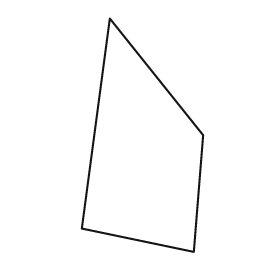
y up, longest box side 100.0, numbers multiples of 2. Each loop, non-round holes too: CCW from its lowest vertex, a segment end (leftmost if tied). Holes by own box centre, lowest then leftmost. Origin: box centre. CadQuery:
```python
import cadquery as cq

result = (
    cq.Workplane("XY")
    .moveTo(22.0, -50.0)
    .lineTo(26.0, 0.0)
    .lineTo(-14.0, 50.0)
    .lineTo(-26.0, -40.0)
    .close()
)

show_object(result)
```